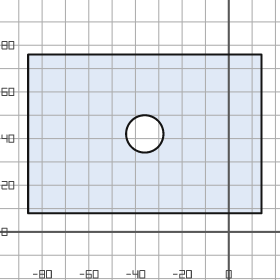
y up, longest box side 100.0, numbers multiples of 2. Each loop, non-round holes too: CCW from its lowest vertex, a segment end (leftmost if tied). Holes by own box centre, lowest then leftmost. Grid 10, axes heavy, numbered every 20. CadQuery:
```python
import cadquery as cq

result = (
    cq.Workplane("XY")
    .moveTo(-86.0, 8.0)
    .lineTo(14.0, 8.0)
    .lineTo(14.0, 76.0)
    .lineTo(-86.0, 76.0)
    .close()
    .moveTo(-36.0, 42.0)
    .circle(8.0)
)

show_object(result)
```